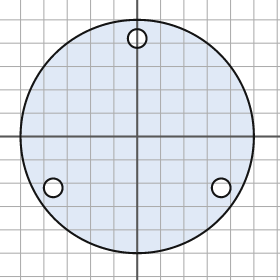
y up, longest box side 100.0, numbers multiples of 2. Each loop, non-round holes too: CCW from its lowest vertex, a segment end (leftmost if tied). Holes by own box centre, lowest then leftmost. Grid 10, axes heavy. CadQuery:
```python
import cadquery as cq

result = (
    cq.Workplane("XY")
    .moveTo(0.0, 0.0)
    .circle(50.0)
    .moveTo(-36.0, -22.0)
    .circle(4.0)
    .moveTo(36.0, -22.0)
    .circle(4.0)
    .moveTo(0.0, 42.0)
    .circle(4.0)
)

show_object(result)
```